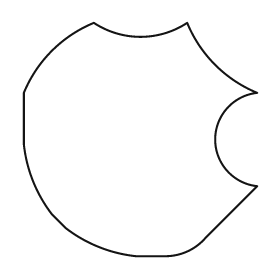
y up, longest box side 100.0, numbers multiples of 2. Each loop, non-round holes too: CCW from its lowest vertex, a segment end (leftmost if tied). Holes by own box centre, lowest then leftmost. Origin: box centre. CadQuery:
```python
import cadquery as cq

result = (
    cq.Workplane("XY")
    .moveTo(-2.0, -50.0)
    .lineTo(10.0, -50.0)
    .threePointArc((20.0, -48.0), (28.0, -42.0))
    .lineTo(50.0, -20.0)
    .threePointArc((32.0, 0.0), (50.0, 20.0))
    .threePointArc((32.0, 32.0), (20.0, 50.0))
    .threePointArc((0.0, 44.0), (-20.0, 50.0))
    .threePointArc((-38.0, 38.0), (-50.0, 20.0))
    .lineTo(-50.0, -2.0)
    .threePointArc((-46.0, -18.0), (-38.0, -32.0))
    .lineTo(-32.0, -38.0)
    .threePointArc((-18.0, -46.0), (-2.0, -50.0))
    .close()
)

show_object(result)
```